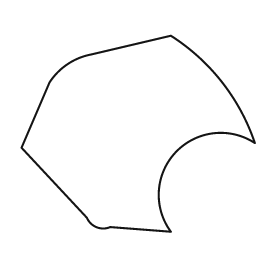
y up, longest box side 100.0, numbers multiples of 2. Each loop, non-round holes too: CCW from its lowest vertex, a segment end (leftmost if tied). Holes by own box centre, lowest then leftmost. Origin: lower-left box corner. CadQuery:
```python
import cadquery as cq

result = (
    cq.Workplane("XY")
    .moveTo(64.0, 0.0)
    .threePointArc((66.0, 34.0), (100.0, 38.0))
    .threePointArc((86.0, 64.0), (64.0, 84.0))
    .lineTo(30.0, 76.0)
    .threePointArc((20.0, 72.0), (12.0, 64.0))
    .lineTo(0.0, 36.0)
    .lineTo(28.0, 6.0)
    .threePointArc((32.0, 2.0), (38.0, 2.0))
    .close()
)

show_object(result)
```